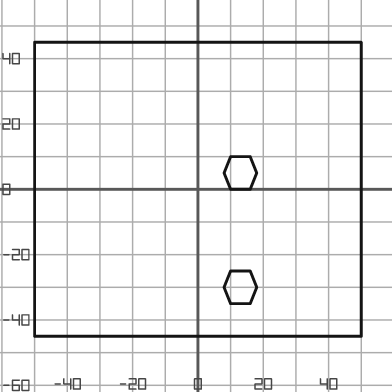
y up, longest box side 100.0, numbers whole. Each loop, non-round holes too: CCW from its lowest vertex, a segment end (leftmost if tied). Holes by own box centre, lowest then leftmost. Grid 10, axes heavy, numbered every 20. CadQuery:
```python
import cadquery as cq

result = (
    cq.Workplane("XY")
    .moveTo(-50.0, -45.0)
    .lineTo(50.0, -45.0)
    .lineTo(50.0, 45.0)
    .lineTo(-50.0, 45.0)
    .close()
    .moveTo(10.0, -35.0)
    .lineTo(16.0, -35.0)
    .lineTo(18.0, -30.0)
    .lineTo(16.0, -25.0)
    .lineTo(10.0, -25.0)
    .lineTo(8.0, -30.0)
    .close()
    .moveTo(10.0, 0.0)
    .lineTo(16.0, 0.0)
    .lineTo(18.0, 5.0)
    .lineTo(16.0, 10.0)
    .lineTo(10.0, 10.0)
    .lineTo(8.0, 5.0)
    .close()
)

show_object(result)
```